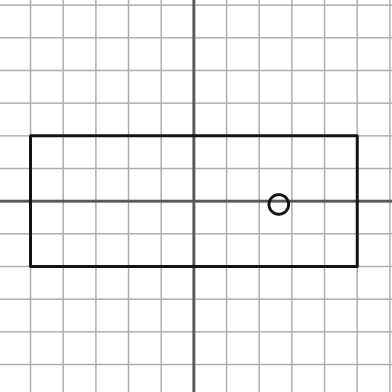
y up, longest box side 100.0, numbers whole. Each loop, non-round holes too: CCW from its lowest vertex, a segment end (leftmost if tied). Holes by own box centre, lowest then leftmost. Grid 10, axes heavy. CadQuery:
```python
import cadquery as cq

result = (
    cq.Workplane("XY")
    .moveTo(-50.0, -20.0)
    .lineTo(50.0, -20.0)
    .lineTo(50.0, 20.0)
    .lineTo(-50.0, 20.0)
    .close()
    .moveTo(26.0, -1.0)
    .circle(3.0)
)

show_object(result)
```